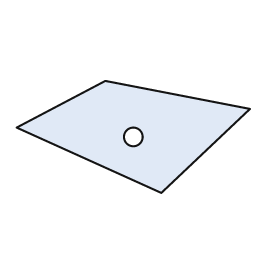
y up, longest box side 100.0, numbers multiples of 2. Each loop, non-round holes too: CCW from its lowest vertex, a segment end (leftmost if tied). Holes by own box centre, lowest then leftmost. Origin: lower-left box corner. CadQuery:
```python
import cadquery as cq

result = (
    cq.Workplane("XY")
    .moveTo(62.0, 0.0)
    .lineTo(100.0, 36.0)
    .lineTo(38.0, 48.0)
    .lineTo(0.0, 28.0)
    .close()
    .moveTo(50.0, 24.0)
    .circle(4.0)
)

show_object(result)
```